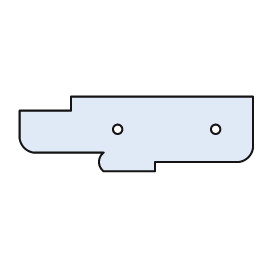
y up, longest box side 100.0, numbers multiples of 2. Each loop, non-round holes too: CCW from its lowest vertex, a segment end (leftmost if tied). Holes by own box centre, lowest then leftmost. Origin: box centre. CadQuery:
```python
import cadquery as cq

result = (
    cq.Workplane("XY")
    .moveTo(-14.0, -16.0)
    .lineTo(8.0, -16.0)
    .lineTo(8.0, -12.0)
    .lineTo(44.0, -12.0)
    .threePointArc((48.0, -10.0), (50.0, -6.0))
    .lineTo(50.0, 16.0)
    .lineTo(-28.0, 16.0)
    .lineTo(-28.0, 10.0)
    .lineTo(-50.0, 10.0)
    .lineTo(-50.0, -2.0)
    .threePointArc((-48.0, -6.0), (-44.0, -8.0))
    .lineTo(-14.0, -8.0)
    .threePointArc((-16.0, -12.0), (-14.0, -16.0))
    .close()
    .moveTo(-8.0, 2.0)
    .circle(2.0)
    .moveTo(34.0, 2.0)
    .circle(2.0)
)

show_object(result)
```